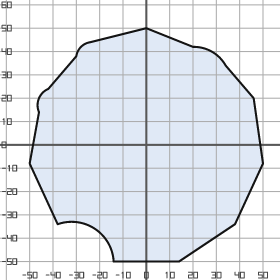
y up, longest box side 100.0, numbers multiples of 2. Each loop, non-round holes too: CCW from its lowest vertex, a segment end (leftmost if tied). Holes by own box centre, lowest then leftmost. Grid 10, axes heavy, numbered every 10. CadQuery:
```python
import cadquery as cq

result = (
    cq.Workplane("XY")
    .moveTo(-14.0, -50.0)
    .lineTo(14.0, -50.0)
    .lineTo(38.0, -34.0)
    .lineTo(50.0, -8.0)
    .lineTo(46.0, 20.0)
    .lineTo(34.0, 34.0)
    .threePointArc((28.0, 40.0), (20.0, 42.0))
    .lineTo(0.0, 50.0)
    .lineTo(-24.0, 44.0)
    .threePointArc((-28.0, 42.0), (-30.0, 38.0))
    .lineTo(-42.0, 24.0)
    .threePointArc((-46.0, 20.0), (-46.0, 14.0))
    .lineTo(-50.0, -8.0)
    .lineTo(-38.0, -34.0)
    .threePointArc((-22.0, -36.0), (-14.0, -50.0))
    .close()
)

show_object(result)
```